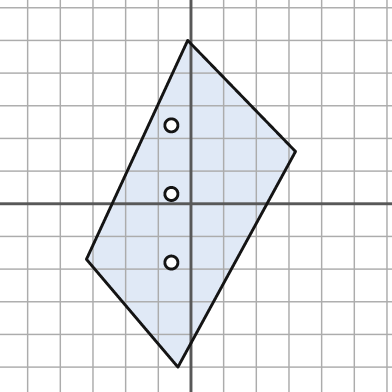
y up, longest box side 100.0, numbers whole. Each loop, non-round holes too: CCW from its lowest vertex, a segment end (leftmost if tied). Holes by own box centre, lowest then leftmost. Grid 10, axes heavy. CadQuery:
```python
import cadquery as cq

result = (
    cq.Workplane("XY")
    .moveTo(-4.0, -50.0)
    .lineTo(32.0, 16.0)
    .lineTo(-1.0, 50.0)
    .lineTo(-32.0, -17.0)
    .close()
    .moveTo(-6.0, -18.0)
    .circle(2.0)
    .moveTo(-6.0, 3.0)
    .circle(2.0)
    .moveTo(-6.0, 24.0)
    .circle(2.0)
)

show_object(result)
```